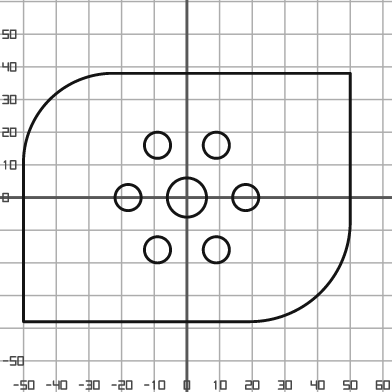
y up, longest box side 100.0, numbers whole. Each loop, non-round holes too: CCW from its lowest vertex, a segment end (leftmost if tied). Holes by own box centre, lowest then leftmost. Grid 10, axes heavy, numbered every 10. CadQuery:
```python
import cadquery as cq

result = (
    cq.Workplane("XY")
    .moveTo(-50.0, -38.0)
    .lineTo(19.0, -38.0)
    .threePointArc((41.0, -29.0), (50.0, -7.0))
    .lineTo(50.0, 38.0)
    .lineTo(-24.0, 38.0)
    .threePointArc((-42.0, 30.0), (-50.0, 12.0))
    .close()
    .moveTo(-9.0, -16.0)
    .circle(4.0)
    .moveTo(9.0, -16.0)
    .circle(4.0)
    .moveTo(-18.0, 0.0)
    .circle(4.0)
    .moveTo(0.0, 0.0)
    .circle(6.0)
    .moveTo(18.0, 0.0)
    .circle(4.0)
    .moveTo(-9.0, 16.0)
    .circle(4.0)
    .moveTo(9.0, 16.0)
    .circle(4.0)
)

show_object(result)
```